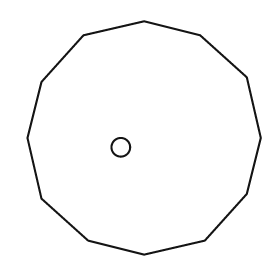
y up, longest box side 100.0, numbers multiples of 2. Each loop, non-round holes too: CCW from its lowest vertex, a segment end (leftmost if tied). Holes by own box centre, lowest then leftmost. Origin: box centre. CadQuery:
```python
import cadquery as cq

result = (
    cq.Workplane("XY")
    .moveTo(0.0, -50.0)
    .lineTo(26.0, -44.0)
    .lineTo(44.0, -24.0)
    .lineTo(50.0, 0.0)
    .lineTo(44.0, 26.0)
    .lineTo(24.0, 44.0)
    .lineTo(0.0, 50.0)
    .lineTo(-26.0, 44.0)
    .lineTo(-44.0, 24.0)
    .lineTo(-50.0, 0.0)
    .lineTo(-44.0, -26.0)
    .lineTo(-24.0, -44.0)
    .close()
    .moveTo(-10.0, -4.0)
    .circle(4.0)
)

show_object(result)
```